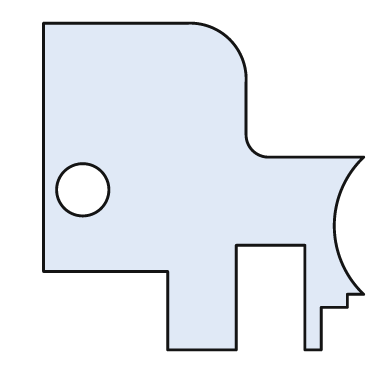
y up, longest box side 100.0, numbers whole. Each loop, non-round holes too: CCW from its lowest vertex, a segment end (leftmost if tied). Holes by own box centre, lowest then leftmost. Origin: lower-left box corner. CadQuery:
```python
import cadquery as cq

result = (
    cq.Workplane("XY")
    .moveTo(38.0, 0.0)
    .lineTo(59.0, 0.0)
    .lineTo(59.0, 32.0)
    .lineTo(80.0, 32.0)
    .lineTo(80.0, 0.0)
    .lineTo(85.0, 0.0)
    .lineTo(85.0, 13.0)
    .lineTo(93.0, 13.0)
    .lineTo(93.0, 17.0)
    .lineTo(98.0, 17.0)
    .threePointArc((89.0, 38.0), (98.0, 59.0))
    .lineTo(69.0, 59.0)
    .threePointArc((64.0, 61.0), (62.0, 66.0))
    .lineTo(62.0, 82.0)
    .threePointArc((57.0, 95.0), (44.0, 100.0))
    .lineTo(0.0, 100.0)
    .lineTo(0.0, 24.0)
    .lineTo(38.0, 24.0)
    .close()
    .moveTo(12.0, 49.0)
    .circle(8.0)
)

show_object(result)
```